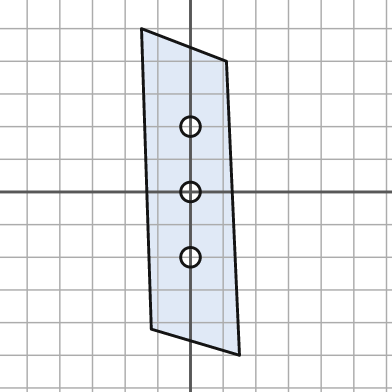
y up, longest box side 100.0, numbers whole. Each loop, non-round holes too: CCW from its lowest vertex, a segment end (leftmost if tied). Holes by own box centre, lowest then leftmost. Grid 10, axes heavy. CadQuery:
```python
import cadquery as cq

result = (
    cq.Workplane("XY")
    .moveTo(15.0, -50.0)
    .lineTo(11.0, 40.0)
    .lineTo(-15.0, 50.0)
    .lineTo(-12.0, -42.0)
    .close()
    .moveTo(0.0, -20.0)
    .circle(3.0)
    .moveTo(0.0, 0.0)
    .circle(3.0)
    .moveTo(0.0, 20.0)
    .circle(3.0)
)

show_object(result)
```